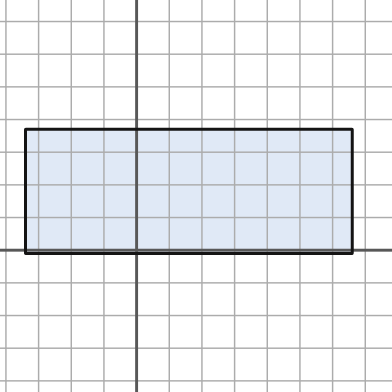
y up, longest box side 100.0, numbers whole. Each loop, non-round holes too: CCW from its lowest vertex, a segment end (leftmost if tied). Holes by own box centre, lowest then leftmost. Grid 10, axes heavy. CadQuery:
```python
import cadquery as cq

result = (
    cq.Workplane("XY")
    .moveTo(-34.0, -1.0)
    .lineTo(66.0, -1.0)
    .lineTo(66.0, 37.0)
    .lineTo(-34.0, 37.0)
    .close()
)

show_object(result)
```